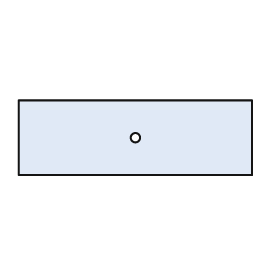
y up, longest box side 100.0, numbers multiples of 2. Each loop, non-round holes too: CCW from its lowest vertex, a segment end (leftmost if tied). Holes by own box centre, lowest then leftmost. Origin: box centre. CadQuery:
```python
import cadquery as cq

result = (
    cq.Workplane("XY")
    .moveTo(-50.0, -16.0)
    .lineTo(50.0, -16.0)
    .lineTo(50.0, 16.0)
    .lineTo(-50.0, 16.0)
    .close()
    .moveTo(0.0, 0.0)
    .circle(2.0)
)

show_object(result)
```